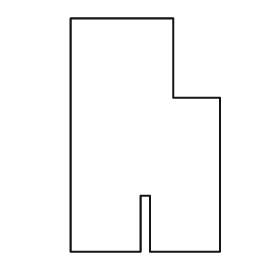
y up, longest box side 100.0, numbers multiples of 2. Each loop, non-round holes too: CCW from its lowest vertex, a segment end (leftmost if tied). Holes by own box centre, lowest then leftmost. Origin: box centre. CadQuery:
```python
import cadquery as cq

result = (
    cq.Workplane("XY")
    .moveTo(-32.0, -50.0)
    .lineTo(-2.0, -50.0)
    .lineTo(-2.0, -26.0)
    .lineTo(2.0, -26.0)
    .lineTo(2.0, -50.0)
    .lineTo(32.0, -50.0)
    .lineTo(32.0, 16.0)
    .lineTo(12.0, 16.0)
    .lineTo(12.0, 50.0)
    .lineTo(-32.0, 50.0)
    .close()
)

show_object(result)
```